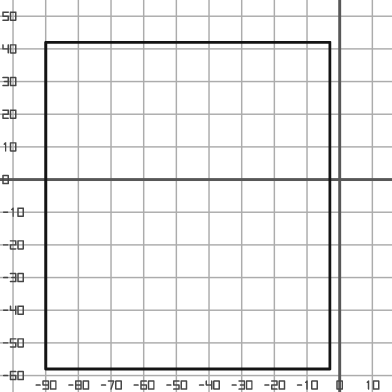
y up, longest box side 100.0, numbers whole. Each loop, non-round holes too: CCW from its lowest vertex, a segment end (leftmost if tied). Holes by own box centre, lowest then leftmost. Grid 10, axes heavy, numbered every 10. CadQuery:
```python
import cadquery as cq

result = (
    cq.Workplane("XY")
    .moveTo(-90.0, -58.0)
    .lineTo(-3.0, -58.0)
    .lineTo(-3.0, 42.0)
    .lineTo(-90.0, 42.0)
    .close()
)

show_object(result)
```